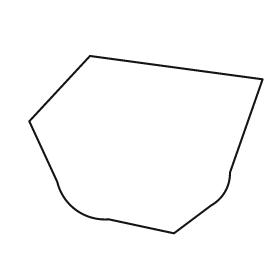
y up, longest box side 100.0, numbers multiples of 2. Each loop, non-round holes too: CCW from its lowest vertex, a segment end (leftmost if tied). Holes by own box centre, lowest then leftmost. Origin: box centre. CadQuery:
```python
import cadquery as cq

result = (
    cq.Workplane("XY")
    .moveTo(12.0, -38.0)
    .lineTo(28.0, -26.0)
    .threePointArc((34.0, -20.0), (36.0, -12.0))
    .lineTo(50.0, 28.0)
    .lineTo(-24.0, 38.0)
    .lineTo(-50.0, 10.0)
    .lineTo(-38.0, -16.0)
    .threePointArc((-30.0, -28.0), (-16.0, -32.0))
    .close()
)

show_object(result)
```